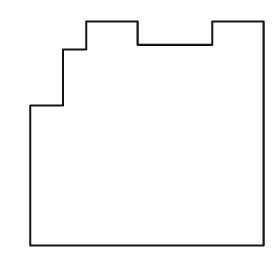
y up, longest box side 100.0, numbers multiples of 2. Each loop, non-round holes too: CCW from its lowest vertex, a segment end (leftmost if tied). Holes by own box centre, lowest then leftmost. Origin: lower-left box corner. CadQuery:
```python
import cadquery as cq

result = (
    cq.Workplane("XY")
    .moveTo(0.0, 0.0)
    .lineTo(100.0, 0.0)
    .lineTo(100.0, 96.0)
    .lineTo(78.0, 96.0)
    .lineTo(78.0, 86.0)
    .lineTo(46.0, 86.0)
    .lineTo(46.0, 96.0)
    .lineTo(24.0, 96.0)
    .lineTo(24.0, 84.0)
    .lineTo(14.0, 84.0)
    .lineTo(14.0, 60.0)
    .lineTo(0.0, 60.0)
    .close()
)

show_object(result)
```